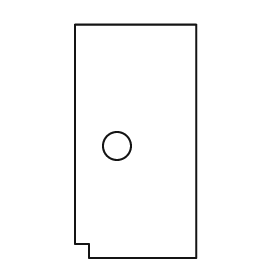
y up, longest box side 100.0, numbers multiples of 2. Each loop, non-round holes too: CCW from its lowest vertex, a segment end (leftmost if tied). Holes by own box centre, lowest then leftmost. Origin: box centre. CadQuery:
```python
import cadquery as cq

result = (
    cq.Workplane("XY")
    .moveTo(-20.0, -50.0)
    .lineTo(26.0, -50.0)
    .lineTo(26.0, 50.0)
    .lineTo(-26.0, 50.0)
    .lineTo(-26.0, -44.0)
    .lineTo(-20.0, -44.0)
    .close()
    .moveTo(-8.0, -2.0)
    .circle(6.0)
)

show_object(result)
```